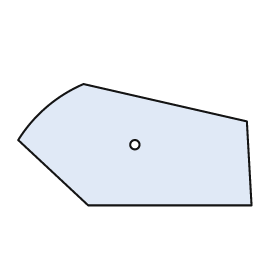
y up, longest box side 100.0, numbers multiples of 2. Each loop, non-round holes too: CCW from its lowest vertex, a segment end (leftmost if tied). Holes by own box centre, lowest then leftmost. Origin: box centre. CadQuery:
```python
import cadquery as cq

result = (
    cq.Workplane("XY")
    .moveTo(-20.0, -26.0)
    .lineTo(50.0, -26.0)
    .lineTo(48.0, 10.0)
    .lineTo(-22.0, 26.0)
    .threePointArc((-38.0, 16.0), (-50.0, 2.0))
    .close()
    .moveTo(0.0, 0.0)
    .circle(2.0)
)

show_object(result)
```